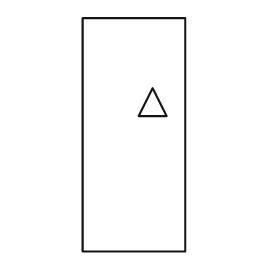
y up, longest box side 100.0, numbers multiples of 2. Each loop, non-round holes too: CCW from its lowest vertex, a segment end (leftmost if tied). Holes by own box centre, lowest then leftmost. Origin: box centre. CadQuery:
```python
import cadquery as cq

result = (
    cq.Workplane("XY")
    .moveTo(-22.0, -50.0)
    .lineTo(22.0, -50.0)
    .lineTo(22.0, 50.0)
    .lineTo(-22.0, 50.0)
    .close()
    .moveTo(2.0, 8.0)
    .lineTo(14.0, 8.0)
    .lineTo(8.0, 20.0)
    .close()
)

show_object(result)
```